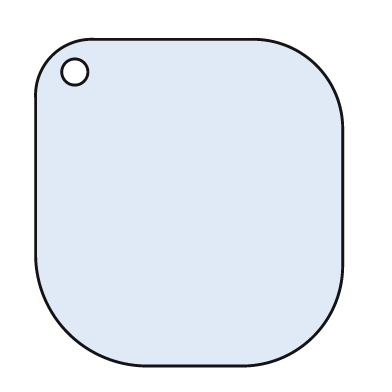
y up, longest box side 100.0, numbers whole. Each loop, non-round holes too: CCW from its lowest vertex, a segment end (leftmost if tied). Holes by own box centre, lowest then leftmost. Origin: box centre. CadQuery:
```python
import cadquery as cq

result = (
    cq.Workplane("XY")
    .moveTo(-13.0, -50.0)
    .lineTo(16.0, -50.0)
    .threePointArc((38.0, -41.0), (47.0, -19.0))
    .lineTo(47.0, 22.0)
    .threePointArc((39.0, 42.0), (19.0, 50.0))
    .lineTo(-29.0, 50.0)
    .threePointArc((-42.0, 45.0), (-47.0, 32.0))
    .lineTo(-47.0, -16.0)
    .threePointArc((-37.0, -40.0), (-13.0, -50.0))
    .close()
    .moveTo(-35.0, 40.0)
    .circle(4.0)
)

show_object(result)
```